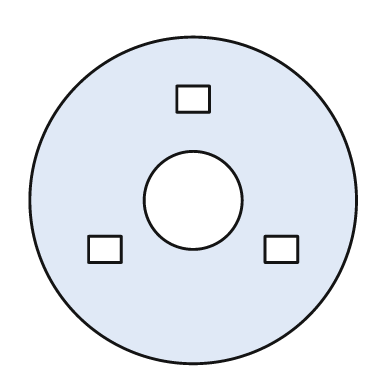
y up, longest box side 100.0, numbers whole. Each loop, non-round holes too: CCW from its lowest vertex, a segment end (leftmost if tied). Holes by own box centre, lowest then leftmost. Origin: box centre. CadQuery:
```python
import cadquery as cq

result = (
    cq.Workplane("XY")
    .moveTo(0.0, 0.0)
    .circle(50.0)
    .moveTo(-32.0, -19.0)
    .lineTo(-22.0, -19.0)
    .lineTo(-22.0, -11.0)
    .lineTo(-32.0, -11.0)
    .close()
    .moveTo(22.0, -19.0)
    .lineTo(32.0, -19.0)
    .lineTo(32.0, -11.0)
    .lineTo(22.0, -11.0)
    .close()
    .moveTo(0.0, 0.0)
    .circle(15.0)
    .moveTo(-5.0, 27.0)
    .lineTo(5.0, 27.0)
    .lineTo(5.0, 35.0)
    .lineTo(-5.0, 35.0)
    .close()
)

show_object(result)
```